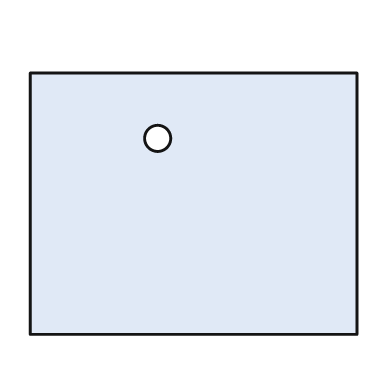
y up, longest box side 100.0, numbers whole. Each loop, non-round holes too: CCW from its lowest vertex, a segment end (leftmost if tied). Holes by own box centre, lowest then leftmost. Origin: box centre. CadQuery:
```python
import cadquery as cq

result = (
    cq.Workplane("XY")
    .moveTo(-50.0, -40.0)
    .lineTo(50.0, -40.0)
    .lineTo(50.0, 40.0)
    .lineTo(-50.0, 40.0)
    .close()
    .moveTo(-11.0, 20.0)
    .circle(4.0)
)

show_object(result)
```